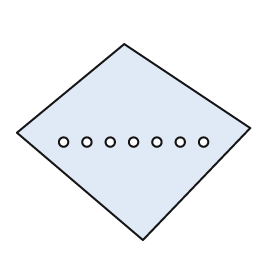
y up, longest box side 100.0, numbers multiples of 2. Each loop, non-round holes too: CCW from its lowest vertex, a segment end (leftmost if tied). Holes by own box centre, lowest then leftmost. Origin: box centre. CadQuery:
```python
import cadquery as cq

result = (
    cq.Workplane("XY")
    .moveTo(4.0, -42.0)
    .lineTo(50.0, 6.0)
    .lineTo(-4.0, 42.0)
    .lineTo(-50.0, 4.0)
    .close()
    .moveTo(-30.0, 0.0)
    .circle(2.0)
    .moveTo(-20.0, 0.0)
    .circle(2.0)
    .moveTo(-10.0, 0.0)
    .circle(2.0)
    .moveTo(0.0, 0.0)
    .circle(2.0)
    .moveTo(10.0, 0.0)
    .circle(2.0)
    .moveTo(20.0, 0.0)
    .circle(2.0)
    .moveTo(30.0, 0.0)
    .circle(2.0)
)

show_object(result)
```